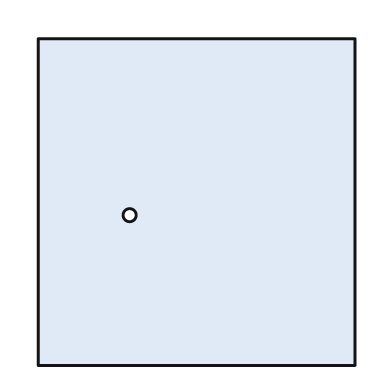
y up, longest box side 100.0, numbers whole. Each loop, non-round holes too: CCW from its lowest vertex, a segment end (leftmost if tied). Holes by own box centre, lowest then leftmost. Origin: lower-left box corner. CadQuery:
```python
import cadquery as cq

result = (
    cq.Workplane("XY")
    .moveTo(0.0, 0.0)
    .lineTo(97.0, 0.0)
    .lineTo(97.0, 100.0)
    .lineTo(0.0, 100.0)
    .close()
    .moveTo(28.0, 46.0)
    .circle(2.0)
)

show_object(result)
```